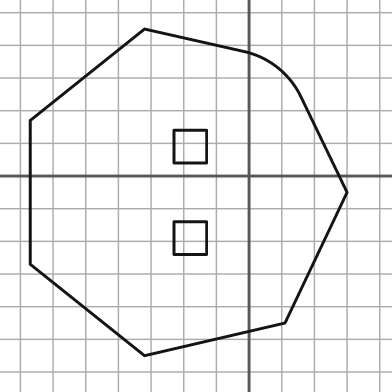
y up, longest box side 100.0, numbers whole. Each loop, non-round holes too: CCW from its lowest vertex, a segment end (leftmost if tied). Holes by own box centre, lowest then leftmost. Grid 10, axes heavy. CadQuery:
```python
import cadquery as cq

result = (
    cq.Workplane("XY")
    .moveTo(-32.0, -55.0)
    .lineTo(11.0, -45.0)
    .lineTo(30.0, -5.0)
    .lineTo(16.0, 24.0)
    .threePointArc((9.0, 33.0), (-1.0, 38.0))
    .lineTo(-32.0, 45.0)
    .lineTo(-67.0, 17.0)
    .lineTo(-67.0, -27.0)
    .close()
    .moveTo(-23.0, -24.0)
    .lineTo(-13.0, -24.0)
    .lineTo(-13.0, -14.0)
    .lineTo(-23.0, -14.0)
    .close()
    .moveTo(-23.0, 4.0)
    .lineTo(-13.0, 4.0)
    .lineTo(-13.0, 14.0)
    .lineTo(-23.0, 14.0)
    .close()
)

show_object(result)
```